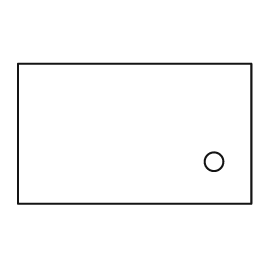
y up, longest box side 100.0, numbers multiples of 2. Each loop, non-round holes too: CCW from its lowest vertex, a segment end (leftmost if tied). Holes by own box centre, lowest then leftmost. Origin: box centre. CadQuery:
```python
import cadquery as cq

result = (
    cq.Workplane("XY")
    .moveTo(-50.0, -30.0)
    .lineTo(50.0, -30.0)
    .lineTo(50.0, 30.0)
    .lineTo(-50.0, 30.0)
    .close()
    .moveTo(34.0, -12.0)
    .circle(4.0)
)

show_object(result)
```